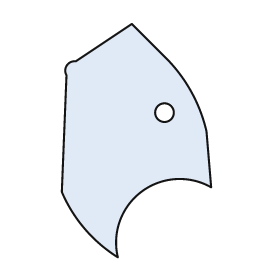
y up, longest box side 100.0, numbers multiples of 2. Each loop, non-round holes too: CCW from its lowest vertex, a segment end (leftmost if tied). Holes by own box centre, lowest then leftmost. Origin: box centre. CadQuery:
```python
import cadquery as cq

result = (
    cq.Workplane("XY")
    .moveTo(-8.0, -50.0)
    .threePointArc((2.0, -22.0), (32.0, -20.0))
    .lineTo(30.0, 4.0)
    .threePointArc((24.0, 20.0), (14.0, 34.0))
    .lineTo(-2.0, 50.0)
    .lineTo(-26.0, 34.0)
    .threePointArc((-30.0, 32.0), (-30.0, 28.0))
    .lineTo(-32.0, -22.0)
    .threePointArc((-22.0, -38.0), (-8.0, -50.0))
    .close()
    .moveTo(12.0, 12.0)
    .circle(4.0)
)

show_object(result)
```